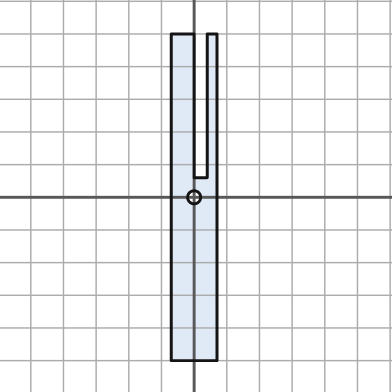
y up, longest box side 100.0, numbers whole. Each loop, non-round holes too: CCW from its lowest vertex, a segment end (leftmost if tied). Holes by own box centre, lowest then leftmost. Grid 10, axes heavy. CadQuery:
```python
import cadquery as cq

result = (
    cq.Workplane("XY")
    .moveTo(-7.0, -50.0)
    .lineTo(7.0, -50.0)
    .lineTo(7.0, 50.0)
    .lineTo(4.0, 50.0)
    .lineTo(4.0, 6.0)
    .lineTo(0.0, 6.0)
    .lineTo(0.0, 50.0)
    .lineTo(-7.0, 50.0)
    .close()
    .moveTo(0.0, 0.0)
    .circle(2.0)
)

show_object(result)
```